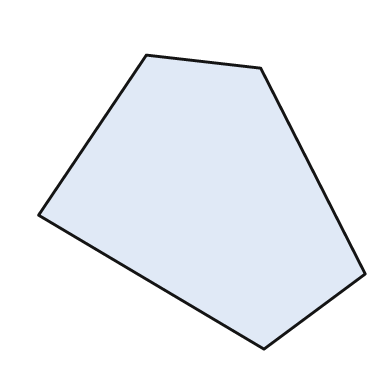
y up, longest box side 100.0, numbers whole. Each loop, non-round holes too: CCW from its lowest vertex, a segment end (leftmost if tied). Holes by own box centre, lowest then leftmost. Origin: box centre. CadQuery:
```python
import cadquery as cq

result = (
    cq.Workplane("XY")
    .moveTo(19.0, -45.0)
    .lineTo(50.0, -22.0)
    .lineTo(18.0, 41.0)
    .lineTo(-17.0, 45.0)
    .lineTo(-50.0, -4.0)
    .close()
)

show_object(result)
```